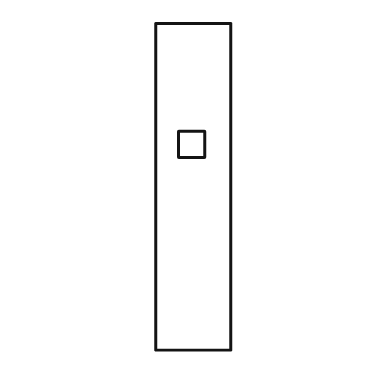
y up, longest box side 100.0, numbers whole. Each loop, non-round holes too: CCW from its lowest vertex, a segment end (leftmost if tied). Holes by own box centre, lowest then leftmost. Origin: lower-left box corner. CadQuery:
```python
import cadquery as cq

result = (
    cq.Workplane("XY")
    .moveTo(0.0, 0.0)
    .lineTo(23.0, 0.0)
    .lineTo(23.0, 100.0)
    .lineTo(0.0, 100.0)
    .close()
    .moveTo(7.0, 59.0)
    .lineTo(15.0, 59.0)
    .lineTo(15.0, 67.0)
    .lineTo(7.0, 67.0)
    .close()
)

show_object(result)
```